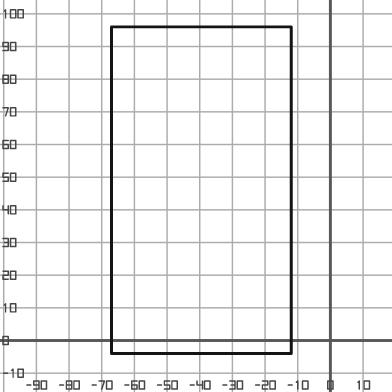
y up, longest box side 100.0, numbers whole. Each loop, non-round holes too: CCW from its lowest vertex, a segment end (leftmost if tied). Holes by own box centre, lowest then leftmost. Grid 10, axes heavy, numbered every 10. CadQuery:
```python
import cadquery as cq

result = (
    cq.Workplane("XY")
    .moveTo(-67.0, -4.0)
    .lineTo(-12.0, -4.0)
    .lineTo(-12.0, 96.0)
    .lineTo(-67.0, 96.0)
    .close()
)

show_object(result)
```